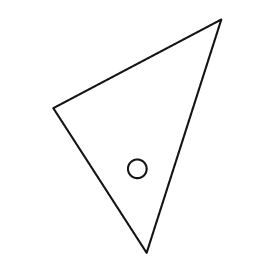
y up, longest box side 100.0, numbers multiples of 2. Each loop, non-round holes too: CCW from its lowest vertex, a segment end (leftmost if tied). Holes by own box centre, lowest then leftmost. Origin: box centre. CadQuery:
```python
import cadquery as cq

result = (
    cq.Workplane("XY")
    .moveTo(4.0, -50.0)
    .lineTo(36.0, 50.0)
    .lineTo(-36.0, 12.0)
    .close()
    .moveTo(0.0, -14.0)
    .circle(4.0)
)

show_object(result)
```